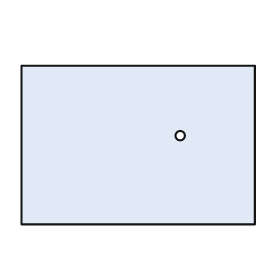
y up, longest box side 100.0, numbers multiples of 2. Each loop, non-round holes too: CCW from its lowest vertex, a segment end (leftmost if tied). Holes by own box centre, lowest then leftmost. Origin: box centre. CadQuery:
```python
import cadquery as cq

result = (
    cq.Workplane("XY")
    .moveTo(-50.0, -34.0)
    .lineTo(50.0, -34.0)
    .lineTo(50.0, 34.0)
    .lineTo(-50.0, 34.0)
    .close()
    .moveTo(18.0, 4.0)
    .circle(2.0)
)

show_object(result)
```